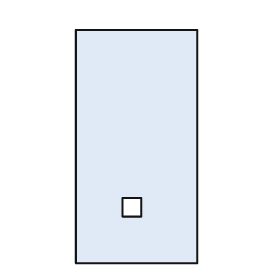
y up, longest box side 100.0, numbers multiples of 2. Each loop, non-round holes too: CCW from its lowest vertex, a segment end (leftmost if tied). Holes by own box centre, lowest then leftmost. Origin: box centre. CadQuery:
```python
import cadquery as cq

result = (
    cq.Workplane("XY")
    .moveTo(-26.0, -50.0)
    .lineTo(26.0, -50.0)
    .lineTo(26.0, 50.0)
    .lineTo(-26.0, 50.0)
    .close()
    .moveTo(-6.0, -30.0)
    .lineTo(2.0, -30.0)
    .lineTo(2.0, -22.0)
    .lineTo(-6.0, -22.0)
    .close()
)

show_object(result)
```